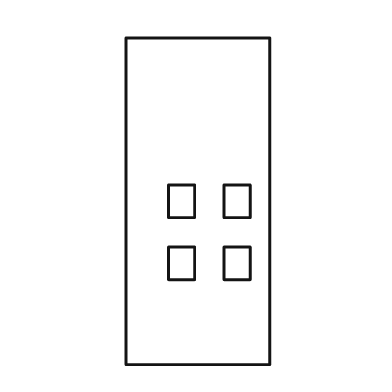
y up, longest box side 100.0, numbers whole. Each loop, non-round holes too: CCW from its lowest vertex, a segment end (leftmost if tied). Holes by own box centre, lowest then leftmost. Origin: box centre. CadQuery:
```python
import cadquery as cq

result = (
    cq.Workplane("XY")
    .moveTo(-22.0, -50.0)
    .lineTo(22.0, -50.0)
    .lineTo(22.0, 50.0)
    .lineTo(-22.0, 50.0)
    .close()
    .moveTo(-9.0, -24.0)
    .lineTo(-1.0, -24.0)
    .lineTo(-1.0, -14.0)
    .lineTo(-9.0, -14.0)
    .close()
    .moveTo(8.0, -24.0)
    .lineTo(16.0, -24.0)
    .lineTo(16.0, -14.0)
    .lineTo(8.0, -14.0)
    .close()
    .moveTo(-9.0, -5.0)
    .lineTo(-1.0, -5.0)
    .lineTo(-1.0, 5.0)
    .lineTo(-9.0, 5.0)
    .close()
    .moveTo(8.0, -5.0)
    .lineTo(16.0, -5.0)
    .lineTo(16.0, 5.0)
    .lineTo(8.0, 5.0)
    .close()
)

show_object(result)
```